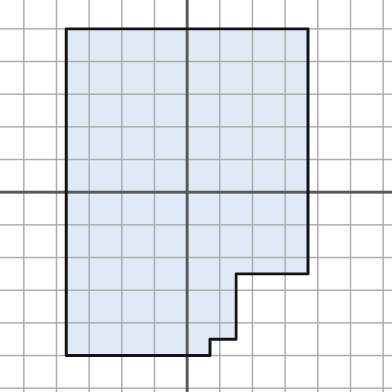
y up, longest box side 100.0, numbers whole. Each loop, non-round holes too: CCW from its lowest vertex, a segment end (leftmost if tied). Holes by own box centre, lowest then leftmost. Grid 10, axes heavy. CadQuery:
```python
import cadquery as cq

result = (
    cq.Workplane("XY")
    .moveTo(-37.0, -50.0)
    .lineTo(7.0, -50.0)
    .lineTo(7.0, -45.0)
    .lineTo(15.0, -45.0)
    .lineTo(15.0, -25.0)
    .lineTo(37.0, -25.0)
    .lineTo(37.0, 50.0)
    .lineTo(-37.0, 50.0)
    .close()
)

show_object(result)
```